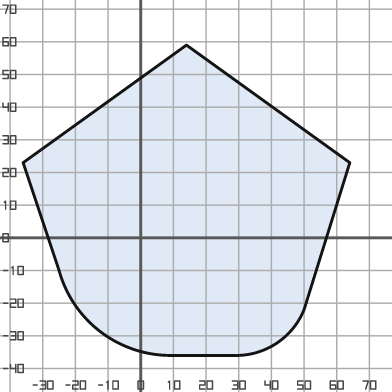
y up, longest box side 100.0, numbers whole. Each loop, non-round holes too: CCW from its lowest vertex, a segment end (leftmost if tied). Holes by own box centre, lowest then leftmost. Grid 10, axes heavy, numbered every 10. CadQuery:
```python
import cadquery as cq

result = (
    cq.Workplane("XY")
    .moveTo(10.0, -36.0)
    .lineTo(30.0, -36.0)
    .threePointArc((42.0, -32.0), (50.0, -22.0))
    .lineTo(64.0, 23.0)
    .lineTo(14.0, 59.0)
    .lineTo(-36.0, 23.0)
    .lineTo(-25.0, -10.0)
    .threePointArc((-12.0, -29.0), (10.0, -36.0))
    .close()
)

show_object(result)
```